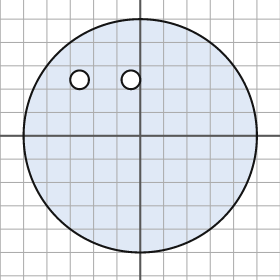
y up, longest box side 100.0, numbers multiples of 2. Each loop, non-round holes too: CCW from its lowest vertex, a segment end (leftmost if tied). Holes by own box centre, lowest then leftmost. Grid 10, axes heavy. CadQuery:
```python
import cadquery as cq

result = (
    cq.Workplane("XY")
    .moveTo(0.0, 0.0)
    .circle(50.0)
    .moveTo(-26.0, 24.0)
    .circle(4.0)
    .moveTo(-4.0, 24.0)
    .circle(4.0)
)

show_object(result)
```